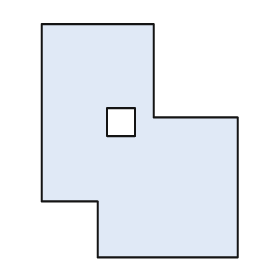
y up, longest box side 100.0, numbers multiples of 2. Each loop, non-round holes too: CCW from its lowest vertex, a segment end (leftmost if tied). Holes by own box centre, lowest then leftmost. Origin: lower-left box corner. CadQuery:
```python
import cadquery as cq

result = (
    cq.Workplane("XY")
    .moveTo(24.0, 0.0)
    .lineTo(84.0, 0.0)
    .lineTo(84.0, 60.0)
    .lineTo(48.0, 60.0)
    .lineTo(48.0, 100.0)
    .lineTo(0.0, 100.0)
    .lineTo(0.0, 24.0)
    .lineTo(24.0, 24.0)
    .close()
    .moveTo(28.0, 52.0)
    .lineTo(40.0, 52.0)
    .lineTo(40.0, 64.0)
    .lineTo(28.0, 64.0)
    .close()
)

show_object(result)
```